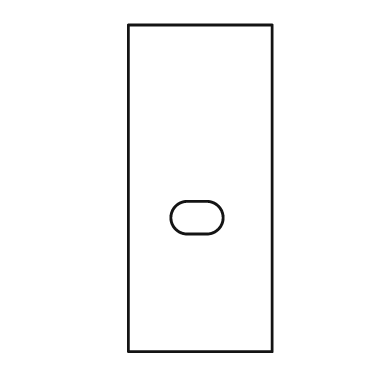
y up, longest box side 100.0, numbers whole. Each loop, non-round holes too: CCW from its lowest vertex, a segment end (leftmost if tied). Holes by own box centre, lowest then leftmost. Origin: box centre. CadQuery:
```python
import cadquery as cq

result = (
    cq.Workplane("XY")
    .moveTo(-22.0, -50.0)
    .lineTo(22.0, -50.0)
    .lineTo(22.0, 50.0)
    .lineTo(-22.0, 50.0)
    .close()
    .moveTo(-4.0, -14.0)
    .lineTo(2.0, -14.0)
    .threePointArc((7.0, -9.0), (2.0, -4.0))
    .lineTo(-4.0, -4.0)
    .threePointArc((-9.0, -9.0), (-4.0, -14.0))
    .close()
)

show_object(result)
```